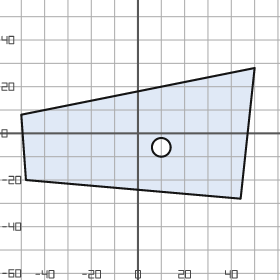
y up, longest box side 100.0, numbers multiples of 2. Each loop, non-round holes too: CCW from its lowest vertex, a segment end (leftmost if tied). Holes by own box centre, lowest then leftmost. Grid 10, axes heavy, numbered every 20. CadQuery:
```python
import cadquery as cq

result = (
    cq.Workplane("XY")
    .moveTo(44.0, -28.0)
    .lineTo(50.0, 28.0)
    .lineTo(-50.0, 8.0)
    .lineTo(-48.0, -20.0)
    .close()
    .moveTo(10.0, -6.0)
    .circle(4.0)
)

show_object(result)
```